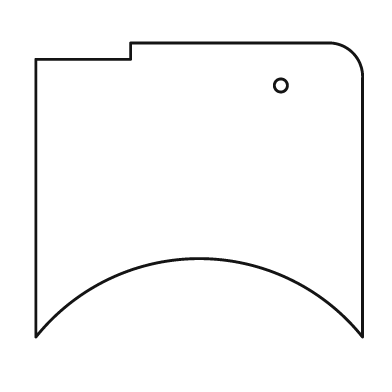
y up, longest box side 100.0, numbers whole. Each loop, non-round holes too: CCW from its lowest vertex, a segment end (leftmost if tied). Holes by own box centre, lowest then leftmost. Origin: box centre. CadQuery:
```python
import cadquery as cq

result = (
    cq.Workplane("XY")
    .moveTo(-50.0, -45.0)
    .threePointArc((0.0, -21.0), (50.0, -45.0))
    .lineTo(50.0, 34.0)
    .threePointArc((47.0, 42.0), (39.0, 45.0))
    .lineTo(-21.0, 45.0)
    .lineTo(-21.0, 40.0)
    .lineTo(-50.0, 40.0)
    .close()
    .moveTo(25.0, 32.0)
    .circle(2.0)
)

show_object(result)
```